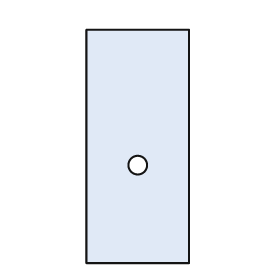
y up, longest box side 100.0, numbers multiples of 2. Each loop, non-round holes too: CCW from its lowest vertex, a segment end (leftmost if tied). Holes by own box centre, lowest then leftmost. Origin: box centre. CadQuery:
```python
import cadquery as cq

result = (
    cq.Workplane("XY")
    .moveTo(-22.0, -50.0)
    .lineTo(22.0, -50.0)
    .lineTo(22.0, 50.0)
    .lineTo(-22.0, 50.0)
    .close()
    .moveTo(0.0, -8.0)
    .circle(4.0)
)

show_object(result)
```